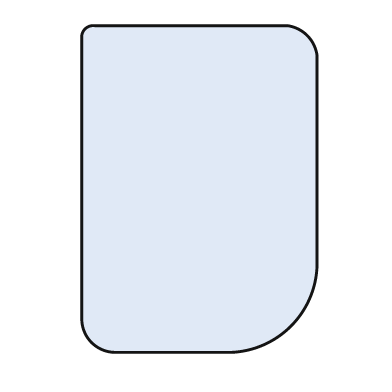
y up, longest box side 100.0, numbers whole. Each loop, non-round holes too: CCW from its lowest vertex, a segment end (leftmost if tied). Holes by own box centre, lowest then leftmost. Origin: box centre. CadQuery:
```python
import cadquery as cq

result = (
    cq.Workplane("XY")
    .moveTo(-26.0, -50.0)
    .lineTo(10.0, -50.0)
    .threePointArc((28.0, -42.0), (36.0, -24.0))
    .lineTo(36.0, 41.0)
    .threePointArc((33.0, 47.0), (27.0, 50.0))
    .lineTo(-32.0, 50.0)
    .threePointArc((-35.0, 49.0), (-36.0, 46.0))
    .lineTo(-36.0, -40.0)
    .threePointArc((-33.0, -47.0), (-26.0, -50.0))
    .close()
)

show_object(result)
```